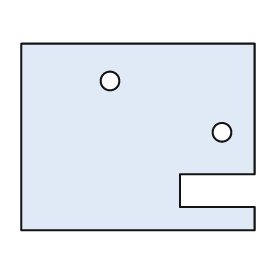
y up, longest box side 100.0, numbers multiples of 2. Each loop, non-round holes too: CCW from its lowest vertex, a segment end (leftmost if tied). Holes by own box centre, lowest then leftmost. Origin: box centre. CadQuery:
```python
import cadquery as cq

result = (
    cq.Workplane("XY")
    .moveTo(-50.0, -40.0)
    .lineTo(50.0, -40.0)
    .lineTo(50.0, -30.0)
    .lineTo(18.0, -30.0)
    .lineTo(18.0, -16.0)
    .lineTo(50.0, -16.0)
    .lineTo(50.0, 40.0)
    .lineTo(-50.0, 40.0)
    .close()
    .moveTo(36.0, 2.0)
    .circle(4.0)
    .moveTo(-12.0, 24.0)
    .circle(4.0)
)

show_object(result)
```